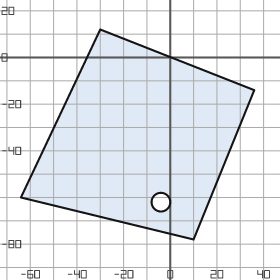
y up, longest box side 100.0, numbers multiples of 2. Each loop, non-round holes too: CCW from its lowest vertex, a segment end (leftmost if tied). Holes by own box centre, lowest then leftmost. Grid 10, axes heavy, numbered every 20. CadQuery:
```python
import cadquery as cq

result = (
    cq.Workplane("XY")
    .moveTo(10.0, -78.0)
    .lineTo(36.0, -14.0)
    .lineTo(-30.0, 12.0)
    .lineTo(-64.0, -60.0)
    .close()
    .moveTo(-4.0, -62.0)
    .circle(4.0)
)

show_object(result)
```